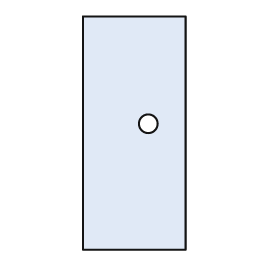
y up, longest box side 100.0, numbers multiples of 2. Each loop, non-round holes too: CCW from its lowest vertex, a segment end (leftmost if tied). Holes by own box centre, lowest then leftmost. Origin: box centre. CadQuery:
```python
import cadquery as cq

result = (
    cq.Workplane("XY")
    .moveTo(-22.0, -50.0)
    .lineTo(22.0, -50.0)
    .lineTo(22.0, 50.0)
    .lineTo(-22.0, 50.0)
    .close()
    .moveTo(6.0, 4.0)
    .circle(4.0)
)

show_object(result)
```